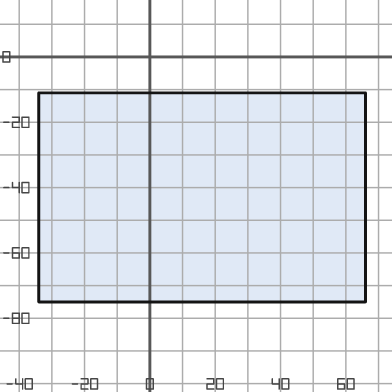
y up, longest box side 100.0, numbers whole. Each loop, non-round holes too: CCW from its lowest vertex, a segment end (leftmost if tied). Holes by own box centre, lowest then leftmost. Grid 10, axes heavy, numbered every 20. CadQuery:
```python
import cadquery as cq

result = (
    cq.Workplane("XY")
    .moveTo(-34.0, -75.0)
    .lineTo(66.0, -75.0)
    .lineTo(66.0, -11.0)
    .lineTo(-34.0, -11.0)
    .close()
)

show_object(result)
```